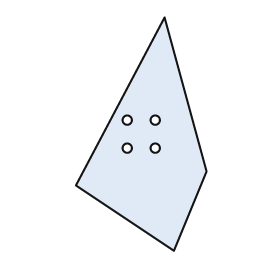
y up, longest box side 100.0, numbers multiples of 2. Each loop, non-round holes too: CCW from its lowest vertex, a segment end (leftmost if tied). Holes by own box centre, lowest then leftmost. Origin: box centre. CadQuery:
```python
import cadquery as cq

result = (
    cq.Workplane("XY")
    .moveTo(14.0, -50.0)
    .lineTo(28.0, -16.0)
    .lineTo(10.0, 50.0)
    .lineTo(-28.0, -22.0)
    .close()
    .moveTo(-6.0, -6.0)
    .circle(2.0)
    .moveTo(6.0, -6.0)
    .circle(2.0)
    .moveTo(-6.0, 6.0)
    .circle(2.0)
    .moveTo(6.0, 6.0)
    .circle(2.0)
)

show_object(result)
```